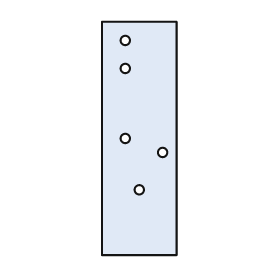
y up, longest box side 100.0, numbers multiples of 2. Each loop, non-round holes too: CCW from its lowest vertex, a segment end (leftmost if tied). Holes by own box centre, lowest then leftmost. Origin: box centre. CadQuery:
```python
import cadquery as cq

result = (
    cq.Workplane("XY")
    .moveTo(-16.0, -50.0)
    .lineTo(16.0, -50.0)
    .lineTo(16.0, 50.0)
    .lineTo(-16.0, 50.0)
    .close()
    .moveTo(0.0, -22.0)
    .circle(2.0)
    .moveTo(10.0, -6.0)
    .circle(2.0)
    .moveTo(-6.0, 0.0)
    .circle(2.0)
    .moveTo(-6.0, 30.0)
    .circle(2.0)
    .moveTo(-6.0, 42.0)
    .circle(2.0)
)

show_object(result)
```